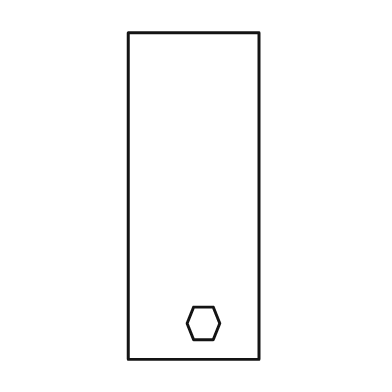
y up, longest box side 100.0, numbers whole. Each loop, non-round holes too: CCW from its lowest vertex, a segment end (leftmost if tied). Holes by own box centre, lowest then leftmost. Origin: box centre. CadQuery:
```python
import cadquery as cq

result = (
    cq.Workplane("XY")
    .moveTo(-20.0, -50.0)
    .lineTo(20.0, -50.0)
    .lineTo(20.0, 50.0)
    .lineTo(-20.0, 50.0)
    .close()
    .moveTo(0.0, -44.0)
    .lineTo(6.0, -44.0)
    .lineTo(8.0, -39.0)
    .lineTo(6.0, -34.0)
    .lineTo(0.0, -34.0)
    .lineTo(-2.0, -39.0)
    .close()
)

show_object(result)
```